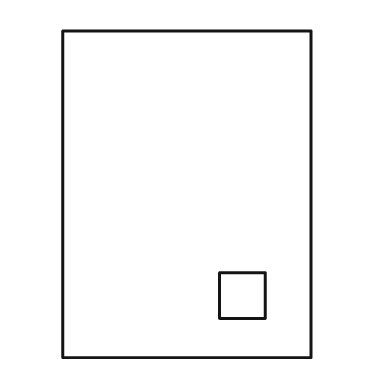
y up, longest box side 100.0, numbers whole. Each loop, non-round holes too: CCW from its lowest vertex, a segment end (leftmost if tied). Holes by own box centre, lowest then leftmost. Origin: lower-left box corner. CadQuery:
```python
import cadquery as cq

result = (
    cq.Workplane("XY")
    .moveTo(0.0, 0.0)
    .lineTo(76.0, 0.0)
    .lineTo(76.0, 100.0)
    .lineTo(0.0, 100.0)
    .close()
    .moveTo(48.0, 12.0)
    .lineTo(62.0, 12.0)
    .lineTo(62.0, 26.0)
    .lineTo(48.0, 26.0)
    .close()
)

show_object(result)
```